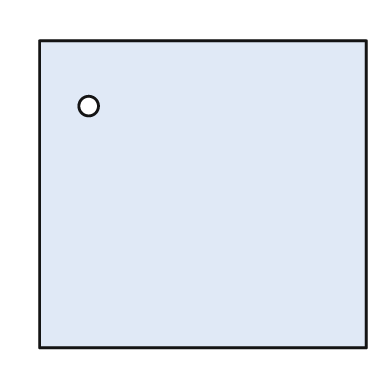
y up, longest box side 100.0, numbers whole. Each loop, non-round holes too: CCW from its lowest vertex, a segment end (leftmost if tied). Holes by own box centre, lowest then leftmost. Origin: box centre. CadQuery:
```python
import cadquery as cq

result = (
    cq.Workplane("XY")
    .moveTo(-50.0, -47.0)
    .lineTo(50.0, -47.0)
    .lineTo(50.0, 47.0)
    .lineTo(-50.0, 47.0)
    .close()
    .moveTo(-35.0, 27.0)
    .circle(3.0)
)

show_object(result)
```